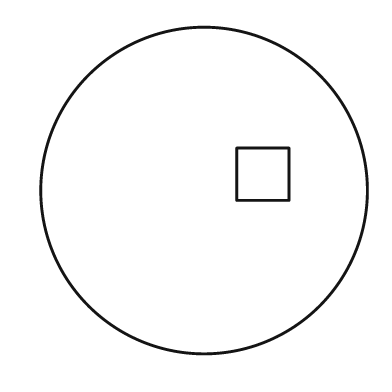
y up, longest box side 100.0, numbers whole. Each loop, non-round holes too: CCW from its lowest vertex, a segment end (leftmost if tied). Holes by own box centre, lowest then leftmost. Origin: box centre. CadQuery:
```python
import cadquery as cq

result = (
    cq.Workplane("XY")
    .moveTo(0.0, 0.0)
    .circle(50.0)
    .moveTo(10.0, -3.0)
    .lineTo(26.0, -3.0)
    .lineTo(26.0, 13.0)
    .lineTo(10.0, 13.0)
    .close()
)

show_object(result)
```